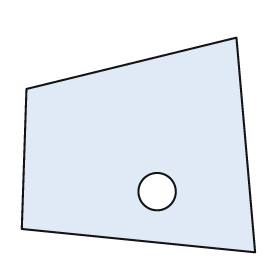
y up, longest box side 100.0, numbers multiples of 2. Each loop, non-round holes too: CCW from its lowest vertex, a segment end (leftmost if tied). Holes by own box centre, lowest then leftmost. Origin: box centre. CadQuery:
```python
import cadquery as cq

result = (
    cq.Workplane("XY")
    .moveTo(50.0, -46.0)
    .lineTo(42.0, 46.0)
    .lineTo(-48.0, 24.0)
    .lineTo(-50.0, -36.0)
    .close()
    .moveTo(8.0, -20.0)
    .circle(8.0)
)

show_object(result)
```